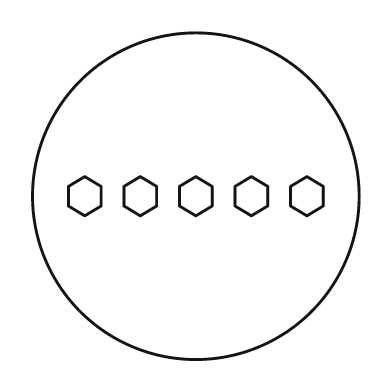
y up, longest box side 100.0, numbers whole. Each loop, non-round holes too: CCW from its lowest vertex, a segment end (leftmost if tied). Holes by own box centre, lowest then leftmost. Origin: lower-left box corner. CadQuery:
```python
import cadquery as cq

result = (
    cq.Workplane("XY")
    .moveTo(50.0, 50.0)
    .circle(50.0)
    .moveTo(16.0, 44.0)
    .lineTo(21.0, 47.0)
    .lineTo(21.0, 53.0)
    .lineTo(16.0, 56.0)
    .lineTo(11.0, 53.0)
    .lineTo(11.0, 47.0)
    .close()
    .moveTo(33.0, 44.0)
    .lineTo(38.0, 47.0)
    .lineTo(38.0, 53.0)
    .lineTo(33.0, 56.0)
    .lineTo(28.0, 53.0)
    .lineTo(28.0, 47.0)
    .close()
    .moveTo(50.0, 44.0)
    .lineTo(55.0, 47.0)
    .lineTo(55.0, 53.0)
    .lineTo(50.0, 56.0)
    .lineTo(45.0, 53.0)
    .lineTo(45.0, 47.0)
    .close()
    .moveTo(67.0, 44.0)
    .lineTo(72.0, 47.0)
    .lineTo(72.0, 53.0)
    .lineTo(67.0, 56.0)
    .lineTo(62.0, 53.0)
    .lineTo(62.0, 47.0)
    .close()
    .moveTo(84.0, 44.0)
    .lineTo(89.0, 47.0)
    .lineTo(89.0, 53.0)
    .lineTo(84.0, 56.0)
    .lineTo(79.0, 53.0)
    .lineTo(79.0, 47.0)
    .close()
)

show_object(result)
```